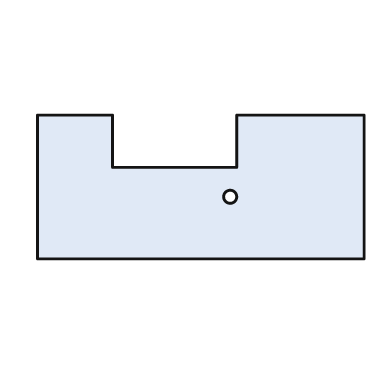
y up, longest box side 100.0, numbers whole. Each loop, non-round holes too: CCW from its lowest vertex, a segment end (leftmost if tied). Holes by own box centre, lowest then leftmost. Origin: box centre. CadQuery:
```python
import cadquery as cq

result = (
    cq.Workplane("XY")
    .moveTo(-50.0, -22.0)
    .lineTo(50.0, -22.0)
    .lineTo(50.0, 22.0)
    .lineTo(11.0, 22.0)
    .lineTo(11.0, 6.0)
    .lineTo(-27.0, 6.0)
    .lineTo(-27.0, 22.0)
    .lineTo(-50.0, 22.0)
    .close()
    .moveTo(9.0, -3.0)
    .circle(2.0)
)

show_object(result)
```